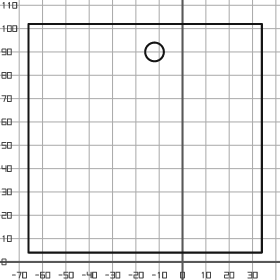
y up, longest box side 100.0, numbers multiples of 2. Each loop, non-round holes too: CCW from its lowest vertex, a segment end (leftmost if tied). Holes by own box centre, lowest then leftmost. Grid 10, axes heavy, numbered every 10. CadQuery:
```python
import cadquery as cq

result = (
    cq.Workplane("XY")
    .moveTo(-66.0, 4.0)
    .lineTo(34.0, 4.0)
    .lineTo(34.0, 102.0)
    .lineTo(-66.0, 102.0)
    .close()
    .moveTo(-12.0, 90.0)
    .circle(4.0)
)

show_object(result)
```